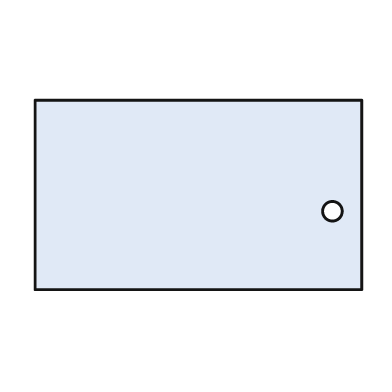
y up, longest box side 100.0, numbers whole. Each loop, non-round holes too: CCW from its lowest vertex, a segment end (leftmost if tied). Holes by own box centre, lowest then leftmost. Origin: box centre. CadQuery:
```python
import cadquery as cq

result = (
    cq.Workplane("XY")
    .moveTo(-50.0, -29.0)
    .lineTo(50.0, -29.0)
    .lineTo(50.0, 29.0)
    .lineTo(-50.0, 29.0)
    .close()
    .moveTo(41.0, -5.0)
    .circle(3.0)
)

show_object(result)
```